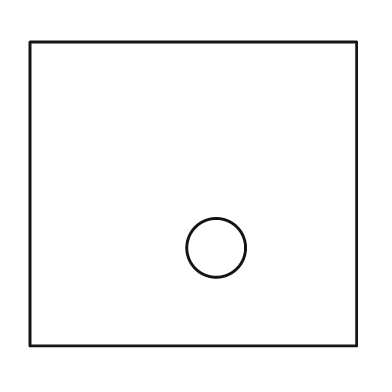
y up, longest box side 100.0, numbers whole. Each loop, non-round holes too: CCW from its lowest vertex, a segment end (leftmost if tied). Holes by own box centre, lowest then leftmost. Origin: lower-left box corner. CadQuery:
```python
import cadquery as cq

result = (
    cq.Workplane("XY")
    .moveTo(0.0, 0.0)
    .lineTo(100.0, 0.0)
    .lineTo(100.0, 93.0)
    .lineTo(0.0, 93.0)
    .close()
    .moveTo(57.0, 30.0)
    .circle(9.0)
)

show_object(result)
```